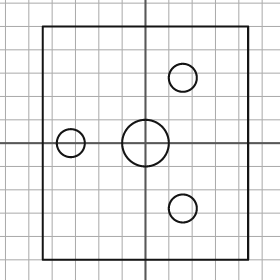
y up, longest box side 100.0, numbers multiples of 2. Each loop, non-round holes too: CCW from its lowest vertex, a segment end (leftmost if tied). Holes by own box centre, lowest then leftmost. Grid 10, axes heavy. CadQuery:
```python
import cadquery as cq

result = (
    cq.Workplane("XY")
    .moveTo(-44.0, -50.0)
    .lineTo(44.0, -50.0)
    .lineTo(44.0, 50.0)
    .lineTo(-44.0, 50.0)
    .close()
    .moveTo(16.0, -28.0)
    .circle(6.0)
    .moveTo(-32.0, 0.0)
    .circle(6.0)
    .moveTo(0.0, 0.0)
    .circle(10.0)
    .moveTo(16.0, 28.0)
    .circle(6.0)
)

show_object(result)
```